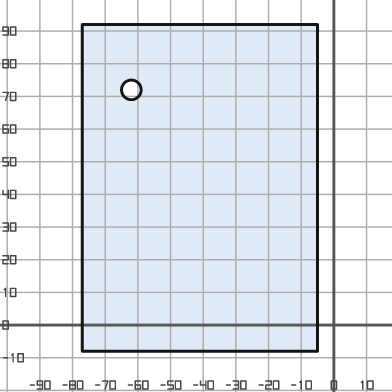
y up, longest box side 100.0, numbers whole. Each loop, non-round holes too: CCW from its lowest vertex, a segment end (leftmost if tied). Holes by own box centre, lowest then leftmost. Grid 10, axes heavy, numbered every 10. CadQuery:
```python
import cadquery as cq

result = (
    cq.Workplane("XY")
    .moveTo(-77.0, -8.0)
    .lineTo(-5.0, -8.0)
    .lineTo(-5.0, 92.0)
    .lineTo(-77.0, 92.0)
    .close()
    .moveTo(-62.0, 72.0)
    .circle(3.0)
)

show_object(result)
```